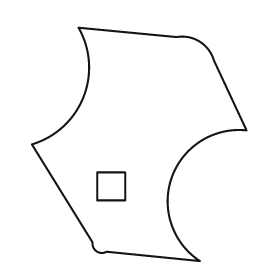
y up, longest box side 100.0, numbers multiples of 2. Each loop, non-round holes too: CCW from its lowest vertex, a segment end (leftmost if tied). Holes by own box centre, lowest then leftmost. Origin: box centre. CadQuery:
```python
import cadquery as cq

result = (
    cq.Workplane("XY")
    .moveTo(26.0, -50.0)
    .threePointArc((14.0, -14.0), (46.0, 6.0))
    .lineTo(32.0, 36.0)
    .threePointArc((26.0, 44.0), (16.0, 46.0))
    .lineTo(-26.0, 50.0)
    .threePointArc((-24.0, 20.0), (-46.0, 0.0))
    .lineTo(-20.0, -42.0)
    .threePointArc((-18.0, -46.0), (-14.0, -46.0))
    .close()
    .moveTo(-18.0, -24.0)
    .lineTo(-6.0, -24.0)
    .lineTo(-6.0, -12.0)
    .lineTo(-18.0, -12.0)
    .close()
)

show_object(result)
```